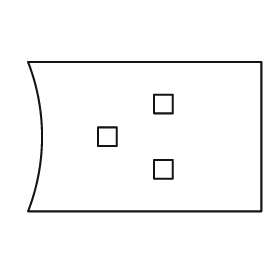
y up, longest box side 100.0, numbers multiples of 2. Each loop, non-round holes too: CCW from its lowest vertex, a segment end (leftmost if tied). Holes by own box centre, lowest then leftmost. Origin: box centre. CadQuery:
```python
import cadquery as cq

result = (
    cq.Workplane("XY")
    .moveTo(-50.0, -32.0)
    .lineTo(50.0, -32.0)
    .lineTo(50.0, 32.0)
    .lineTo(-50.0, 32.0)
    .threePointArc((-44.0, 0.0), (-50.0, -32.0))
    .close()
    .moveTo(4.0, -18.0)
    .lineTo(12.0, -18.0)
    .lineTo(12.0, -10.0)
    .lineTo(4.0, -10.0)
    .close()
    .moveTo(-20.0, -4.0)
    .lineTo(-12.0, -4.0)
    .lineTo(-12.0, 4.0)
    .lineTo(-20.0, 4.0)
    .close()
    .moveTo(4.0, 10.0)
    .lineTo(12.0, 10.0)
    .lineTo(12.0, 18.0)
    .lineTo(4.0, 18.0)
    .close()
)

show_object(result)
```